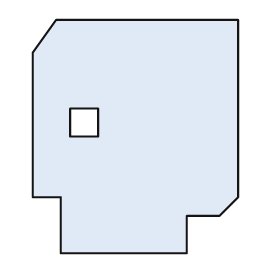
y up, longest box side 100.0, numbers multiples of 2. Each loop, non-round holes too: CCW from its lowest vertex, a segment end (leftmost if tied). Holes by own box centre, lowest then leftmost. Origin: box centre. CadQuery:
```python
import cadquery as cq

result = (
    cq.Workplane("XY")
    .moveTo(-32.0, -50.0)
    .lineTo(22.0, -50.0)
    .lineTo(22.0, -34.0)
    .lineTo(36.0, -34.0)
    .lineTo(44.0, -26.0)
    .lineTo(44.0, 50.0)
    .lineTo(-34.0, 50.0)
    .lineTo(-44.0, 36.0)
    .lineTo(-44.0, -26.0)
    .lineTo(-32.0, -26.0)
    .close()
    .moveTo(-28.0, 0.0)
    .lineTo(-16.0, 0.0)
    .lineTo(-16.0, 12.0)
    .lineTo(-28.0, 12.0)
    .close()
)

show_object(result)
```